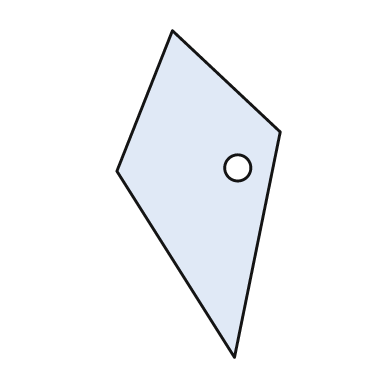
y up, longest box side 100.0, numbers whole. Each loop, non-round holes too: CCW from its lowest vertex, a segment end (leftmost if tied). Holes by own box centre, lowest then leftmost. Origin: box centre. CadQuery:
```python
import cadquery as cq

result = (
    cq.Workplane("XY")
    .moveTo(11.0, -50.0)
    .lineTo(25.0, 19.0)
    .lineTo(-8.0, 50.0)
    .lineTo(-25.0, 7.0)
    .close()
    .moveTo(12.0, 8.0)
    .circle(4.0)
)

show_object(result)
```